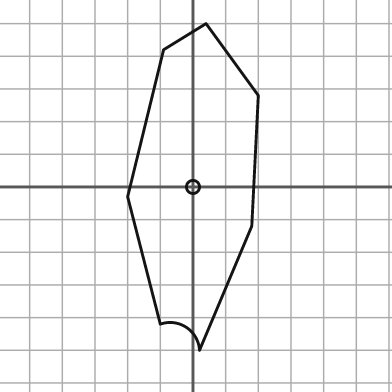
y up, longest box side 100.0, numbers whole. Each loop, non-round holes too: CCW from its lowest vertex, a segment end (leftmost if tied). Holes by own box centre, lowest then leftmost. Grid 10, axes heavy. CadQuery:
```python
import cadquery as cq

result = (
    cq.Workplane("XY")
    .moveTo(2.0, -50.0)
    .lineTo(18.0, -12.0)
    .lineTo(20.0, 28.0)
    .lineTo(4.0, 50.0)
    .lineTo(-9.0, 42.0)
    .lineTo(-20.0, -3.0)
    .lineTo(-10.0, -42.0)
    .threePointArc((-2.0, -43.0), (2.0, -50.0))
    .close()
    .moveTo(0.0, 0.0)
    .circle(2.0)
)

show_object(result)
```